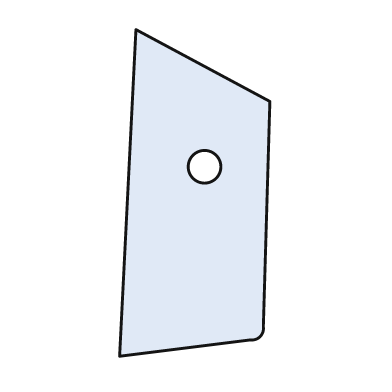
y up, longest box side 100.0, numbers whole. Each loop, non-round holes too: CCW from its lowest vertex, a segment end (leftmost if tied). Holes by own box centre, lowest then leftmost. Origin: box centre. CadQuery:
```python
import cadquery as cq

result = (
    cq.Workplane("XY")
    .moveTo(-23.0, -50.0)
    .lineTo(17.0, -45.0)
    .threePointArc((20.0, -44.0), (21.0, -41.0))
    .lineTo(23.0, 28.0)
    .lineTo(-18.0, 50.0)
    .close()
    .moveTo(3.0, 8.0)
    .circle(5.0)
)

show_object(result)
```